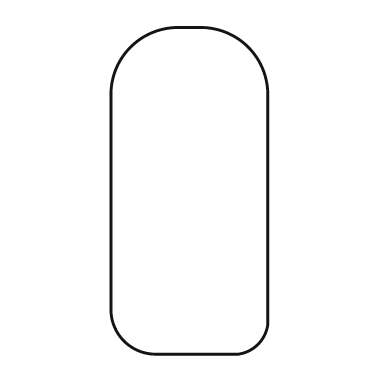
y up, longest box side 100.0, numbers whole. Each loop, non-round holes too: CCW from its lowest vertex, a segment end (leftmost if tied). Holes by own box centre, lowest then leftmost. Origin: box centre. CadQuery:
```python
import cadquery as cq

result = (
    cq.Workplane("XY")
    .moveTo(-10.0, -50.0)
    .lineTo(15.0, -50.0)
    .threePointArc((21.0, -47.0), (24.0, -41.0))
    .lineTo(24.0, 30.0)
    .threePointArc((18.0, 44.0), (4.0, 50.0))
    .lineTo(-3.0, 50.0)
    .threePointArc((-18.0, 44.0), (-24.0, 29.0))
    .lineTo(-24.0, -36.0)
    .threePointArc((-20.0, -46.0), (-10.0, -50.0))
    .close()
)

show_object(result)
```